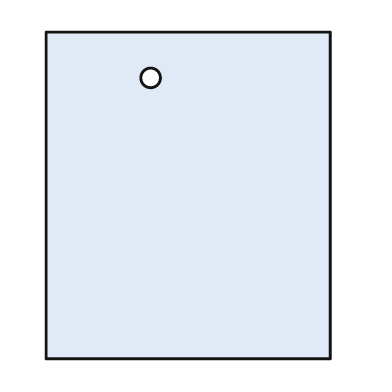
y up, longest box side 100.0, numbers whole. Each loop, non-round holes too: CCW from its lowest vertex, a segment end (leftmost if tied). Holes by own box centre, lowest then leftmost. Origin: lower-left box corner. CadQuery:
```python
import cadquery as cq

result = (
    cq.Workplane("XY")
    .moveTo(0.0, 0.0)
    .lineTo(87.0, 0.0)
    .lineTo(87.0, 100.0)
    .lineTo(0.0, 100.0)
    .close()
    .moveTo(32.0, 86.0)
    .circle(3.0)
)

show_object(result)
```